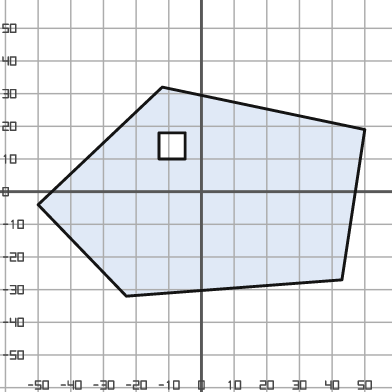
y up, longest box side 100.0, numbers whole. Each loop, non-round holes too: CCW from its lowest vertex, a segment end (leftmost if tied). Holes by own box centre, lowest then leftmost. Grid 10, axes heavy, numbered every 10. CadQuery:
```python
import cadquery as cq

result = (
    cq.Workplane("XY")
    .moveTo(-23.0, -32.0)
    .lineTo(43.0, -27.0)
    .lineTo(50.0, 19.0)
    .lineTo(-12.0, 32.0)
    .lineTo(-50.0, -4.0)
    .close()
    .moveTo(-13.0, 10.0)
    .lineTo(-5.0, 10.0)
    .lineTo(-5.0, 18.0)
    .lineTo(-13.0, 18.0)
    .close()
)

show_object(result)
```